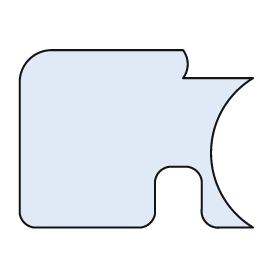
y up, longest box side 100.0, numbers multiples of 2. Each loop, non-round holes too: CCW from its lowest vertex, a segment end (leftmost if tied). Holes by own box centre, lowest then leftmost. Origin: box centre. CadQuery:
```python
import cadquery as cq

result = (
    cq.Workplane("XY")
    .moveTo(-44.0, -38.0)
    .lineTo(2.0, -38.0)
    .threePointArc((6.0, -36.0), (8.0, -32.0))
    .lineTo(8.0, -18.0)
    .threePointArc((10.0, -14.0), (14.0, -12.0))
    .lineTo(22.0, -12.0)
    .threePointArc((26.0, -14.0), (28.0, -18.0))
    .lineTo(28.0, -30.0)
    .threePointArc((30.0, -36.0), (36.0, -38.0))
    .lineTo(50.0, -38.0)
    .threePointArc((32.0, -6.0), (50.0, 26.0))
    .lineTo(20.0, 26.0)
    .threePointArc((22.0, 32.0), (20.0, 38.0))
    .lineTo(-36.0, 38.0)
    .threePointArc((-46.0, 34.0), (-50.0, 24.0))
    .lineTo(-50.0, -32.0)
    .threePointArc((-48.0, -36.0), (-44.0, -38.0))
    .close()
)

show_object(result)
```